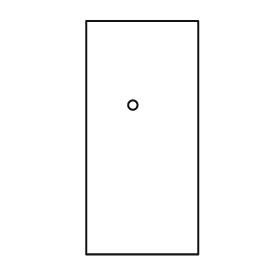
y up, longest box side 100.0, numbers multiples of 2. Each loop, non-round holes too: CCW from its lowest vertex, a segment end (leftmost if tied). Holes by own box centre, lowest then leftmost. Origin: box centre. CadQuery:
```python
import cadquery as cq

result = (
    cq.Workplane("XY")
    .moveTo(-24.0, -50.0)
    .lineTo(24.0, -50.0)
    .lineTo(24.0, 50.0)
    .lineTo(-24.0, 50.0)
    .close()
    .moveTo(-4.0, 14.0)
    .circle(2.0)
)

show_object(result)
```